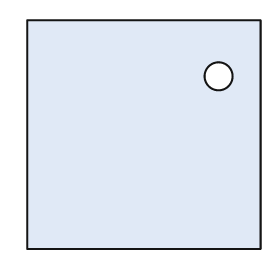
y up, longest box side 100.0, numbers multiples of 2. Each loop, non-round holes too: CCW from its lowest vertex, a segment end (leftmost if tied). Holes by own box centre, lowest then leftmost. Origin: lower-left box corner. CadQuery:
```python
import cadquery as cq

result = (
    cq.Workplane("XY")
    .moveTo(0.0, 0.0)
    .lineTo(100.0, 0.0)
    .lineTo(100.0, 98.0)
    .lineTo(0.0, 98.0)
    .close()
    .moveTo(82.0, 74.0)
    .circle(6.0)
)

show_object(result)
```